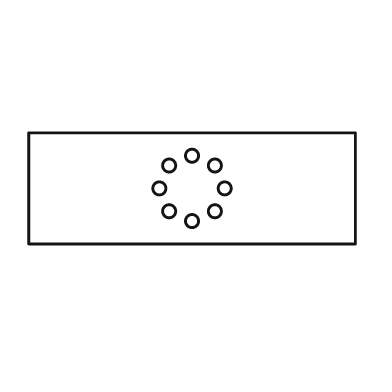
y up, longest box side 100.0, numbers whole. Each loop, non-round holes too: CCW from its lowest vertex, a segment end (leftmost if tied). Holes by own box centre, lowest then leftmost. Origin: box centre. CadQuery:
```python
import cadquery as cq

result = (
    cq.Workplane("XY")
    .moveTo(-50.0, -17.0)
    .lineTo(50.0, -17.0)
    .lineTo(50.0, 17.0)
    .lineTo(-50.0, 17.0)
    .close()
    .moveTo(0.0, -10.0)
    .circle(2.0)
    .moveTo(-7.0, -7.0)
    .circle(2.0)
    .moveTo(7.0, -7.0)
    .circle(2.0)
    .moveTo(-10.0, 0.0)
    .circle(2.0)
    .moveTo(10.0, 0.0)
    .circle(2.0)
    .moveTo(-7.0, 7.0)
    .circle(2.0)
    .moveTo(7.0, 7.0)
    .circle(2.0)
    .moveTo(0.0, 10.0)
    .circle(2.0)
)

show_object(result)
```